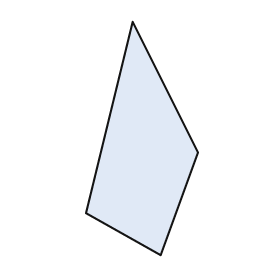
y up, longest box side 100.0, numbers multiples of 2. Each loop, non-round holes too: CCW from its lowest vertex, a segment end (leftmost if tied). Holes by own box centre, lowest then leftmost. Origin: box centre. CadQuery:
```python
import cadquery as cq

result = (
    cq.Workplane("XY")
    .moveTo(8.0, -50.0)
    .lineTo(24.0, -6.0)
    .lineTo(-4.0, 50.0)
    .lineTo(-24.0, -32.0)
    .close()
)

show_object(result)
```